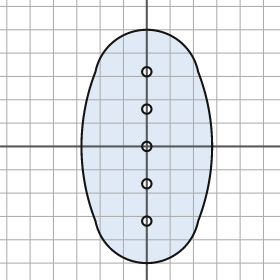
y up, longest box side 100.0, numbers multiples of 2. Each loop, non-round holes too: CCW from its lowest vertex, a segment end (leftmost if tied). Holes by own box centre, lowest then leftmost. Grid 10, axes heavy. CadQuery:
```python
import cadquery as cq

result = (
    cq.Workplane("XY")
    .moveTo(-22.0, -32.0)
    .threePointArc((0.0, -50.0), (22.0, -32.0))
    .threePointArc((28.0, 0.0), (22.0, 32.0))
    .threePointArc((0.0, 50.0), (-22.0, 32.0))
    .threePointArc((-28.0, 0.0), (-22.0, -32.0))
    .close()
    .moveTo(0.0, -32.0)
    .circle(2.0)
    .moveTo(0.0, -16.0)
    .circle(2.0)
    .moveTo(0.0, 0.0)
    .circle(2.0)
    .moveTo(0.0, 16.0)
    .circle(2.0)
    .moveTo(0.0, 32.0)
    .circle(2.0)
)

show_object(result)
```